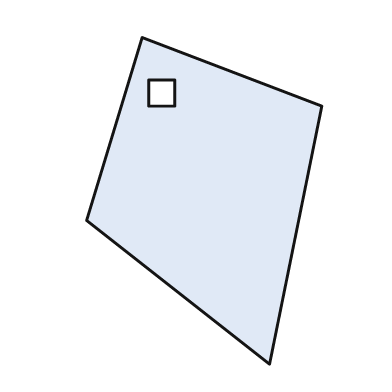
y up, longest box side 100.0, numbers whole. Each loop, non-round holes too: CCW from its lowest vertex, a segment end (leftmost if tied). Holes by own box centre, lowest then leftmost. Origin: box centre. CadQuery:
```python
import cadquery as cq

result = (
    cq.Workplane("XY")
    .moveTo(20.0, -50.0)
    .lineTo(36.0, 29.0)
    .lineTo(-19.0, 50.0)
    .lineTo(-36.0, -6.0)
    .close()
    .moveTo(-17.0, 29.0)
    .lineTo(-9.0, 29.0)
    .lineTo(-9.0, 37.0)
    .lineTo(-17.0, 37.0)
    .close()
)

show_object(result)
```